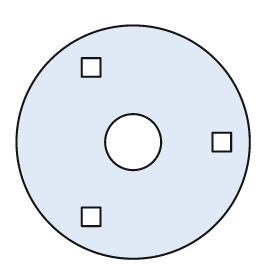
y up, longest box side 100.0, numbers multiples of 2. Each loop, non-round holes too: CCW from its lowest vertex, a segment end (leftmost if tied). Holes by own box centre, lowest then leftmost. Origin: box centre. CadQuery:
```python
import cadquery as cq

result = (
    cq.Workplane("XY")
    .moveTo(0.0, 0.0)
    .circle(50.0)
    .moveTo(-22.0, -36.0)
    .lineTo(-14.0, -36.0)
    .lineTo(-14.0, -28.0)
    .lineTo(-22.0, -28.0)
    .close()
    .moveTo(0.0, 0.0)
    .circle(12.0)
    .moveTo(34.0, -4.0)
    .lineTo(42.0, -4.0)
    .lineTo(42.0, 4.0)
    .lineTo(34.0, 4.0)
    .close()
    .moveTo(-22.0, 28.0)
    .lineTo(-14.0, 28.0)
    .lineTo(-14.0, 36.0)
    .lineTo(-22.0, 36.0)
    .close()
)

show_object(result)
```